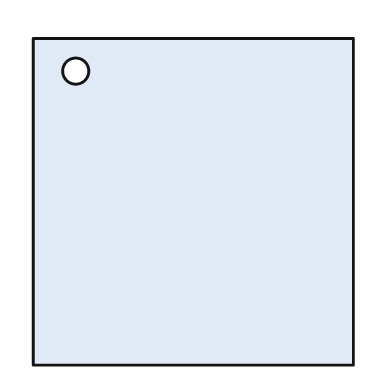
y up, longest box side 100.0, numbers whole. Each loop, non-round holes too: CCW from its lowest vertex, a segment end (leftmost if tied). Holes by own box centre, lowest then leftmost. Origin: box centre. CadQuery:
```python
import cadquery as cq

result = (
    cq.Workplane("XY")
    .moveTo(-49.0, -50.0)
    .lineTo(49.0, -50.0)
    .lineTo(49.0, 50.0)
    .lineTo(-49.0, 50.0)
    .close()
    .moveTo(-36.0, 40.0)
    .circle(4.0)
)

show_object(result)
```